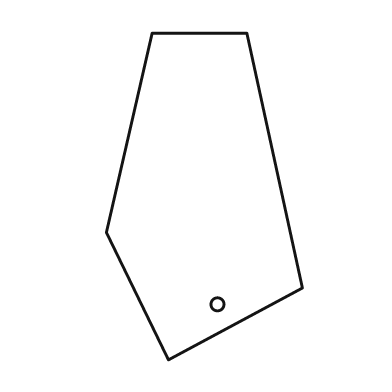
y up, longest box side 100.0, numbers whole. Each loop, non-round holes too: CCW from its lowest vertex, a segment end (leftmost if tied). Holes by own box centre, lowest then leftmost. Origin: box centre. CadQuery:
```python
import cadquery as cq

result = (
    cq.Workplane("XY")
    .moveTo(-11.0, -50.0)
    .lineTo(30.0, -28.0)
    .lineTo(13.0, 50.0)
    .lineTo(-16.0, 50.0)
    .lineTo(-30.0, -11.0)
    .close()
    .moveTo(4.0, -33.0)
    .circle(2.0)
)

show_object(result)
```